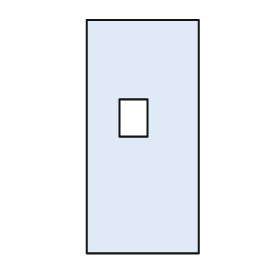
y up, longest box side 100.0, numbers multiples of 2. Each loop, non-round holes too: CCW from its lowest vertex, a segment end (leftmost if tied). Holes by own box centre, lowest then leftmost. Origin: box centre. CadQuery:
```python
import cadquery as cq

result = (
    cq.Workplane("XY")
    .moveTo(-24.0, -50.0)
    .lineTo(24.0, -50.0)
    .lineTo(24.0, 50.0)
    .lineTo(-24.0, 50.0)
    .close()
    .moveTo(-10.0, 0.0)
    .lineTo(2.0, 0.0)
    .lineTo(2.0, 16.0)
    .lineTo(-10.0, 16.0)
    .close()
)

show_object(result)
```